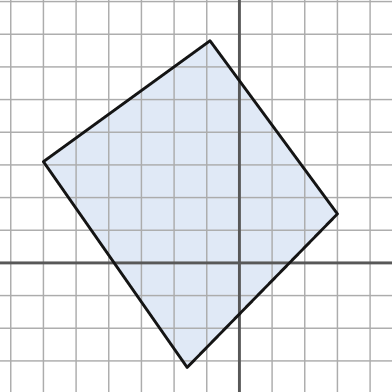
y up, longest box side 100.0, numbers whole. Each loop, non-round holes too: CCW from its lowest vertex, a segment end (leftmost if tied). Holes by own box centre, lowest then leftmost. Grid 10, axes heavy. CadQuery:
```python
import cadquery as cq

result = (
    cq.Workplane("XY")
    .moveTo(-16.0, -32.0)
    .lineTo(30.0, 15.0)
    .lineTo(-9.0, 68.0)
    .lineTo(-60.0, 31.0)
    .close()
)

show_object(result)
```